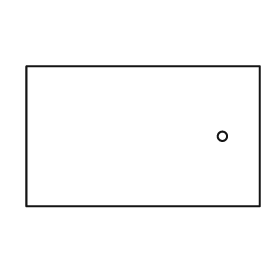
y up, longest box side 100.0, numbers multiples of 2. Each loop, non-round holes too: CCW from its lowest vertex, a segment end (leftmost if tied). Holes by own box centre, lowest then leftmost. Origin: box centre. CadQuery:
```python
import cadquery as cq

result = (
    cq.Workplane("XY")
    .moveTo(-50.0, -30.0)
    .lineTo(50.0, -30.0)
    .lineTo(50.0, 30.0)
    .lineTo(-50.0, 30.0)
    .close()
    .moveTo(34.0, 0.0)
    .circle(2.0)
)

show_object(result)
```